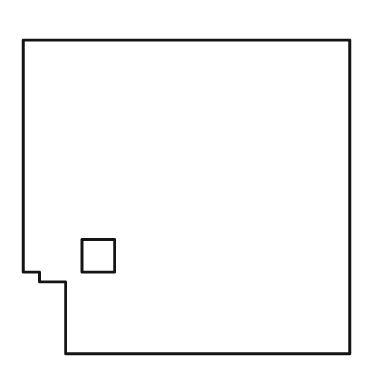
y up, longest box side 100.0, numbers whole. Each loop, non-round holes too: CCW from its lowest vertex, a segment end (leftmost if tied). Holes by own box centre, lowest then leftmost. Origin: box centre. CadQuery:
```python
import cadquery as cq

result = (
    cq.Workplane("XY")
    .moveTo(-37.0, -48.0)
    .lineTo(50.0, -48.0)
    .lineTo(50.0, 48.0)
    .lineTo(-50.0, 48.0)
    .lineTo(-50.0, -23.0)
    .lineTo(-45.0, -23.0)
    .lineTo(-45.0, -26.0)
    .lineTo(-37.0, -26.0)
    .close()
    .moveTo(-32.0, -23.0)
    .lineTo(-22.0, -23.0)
    .lineTo(-22.0, -13.0)
    .lineTo(-32.0, -13.0)
    .close()
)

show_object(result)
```